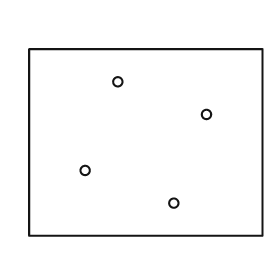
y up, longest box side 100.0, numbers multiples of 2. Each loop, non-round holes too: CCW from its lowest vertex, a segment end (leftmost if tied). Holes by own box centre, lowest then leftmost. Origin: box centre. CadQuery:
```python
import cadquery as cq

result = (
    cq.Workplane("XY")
    .moveTo(-50.0, -40.0)
    .lineTo(50.0, -40.0)
    .lineTo(50.0, 40.0)
    .lineTo(-50.0, 40.0)
    .close()
    .moveTo(12.0, -26.0)
    .circle(2.0)
    .moveTo(-26.0, -12.0)
    .circle(2.0)
    .moveTo(26.0, 12.0)
    .circle(2.0)
    .moveTo(-12.0, 26.0)
    .circle(2.0)
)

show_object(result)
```